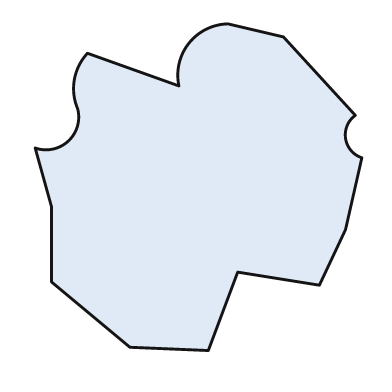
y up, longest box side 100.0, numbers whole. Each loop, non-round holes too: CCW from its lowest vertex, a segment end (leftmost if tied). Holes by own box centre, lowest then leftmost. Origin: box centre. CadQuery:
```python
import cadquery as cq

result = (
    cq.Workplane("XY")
    .moveTo(3.0, -50.0)
    .lineTo(12.0, -26.0)
    .lineTo(37.0, -30.0)
    .lineTo(45.0, -13.0)
    .lineTo(50.0, 9.0)
    .threePointArc((45.0, 15.0), (48.0, 22.0))
    .lineTo(26.0, 46.0)
    .lineTo(9.0, 50.0)
    .threePointArc((-3.0, 44.0), (-6.0, 31.0))
    .lineTo(-34.0, 41.0)
    .threePointArc((-38.0, 33.0), (-37.0, 24.0))
    .threePointArc((-40.0, 14.0), (-50.0, 12.0))
    .lineTo(-45.0, -6.0)
    .lineTo(-45.0, -29.0)
    .lineTo(-21.0, -49.0)
    .close()
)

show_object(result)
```